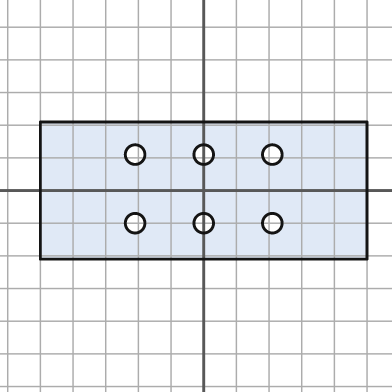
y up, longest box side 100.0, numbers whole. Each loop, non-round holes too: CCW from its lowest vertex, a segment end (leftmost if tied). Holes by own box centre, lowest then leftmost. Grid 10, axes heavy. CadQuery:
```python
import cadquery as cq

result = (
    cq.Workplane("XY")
    .moveTo(-50.0, -21.0)
    .lineTo(50.0, -21.0)
    .lineTo(50.0, 21.0)
    .lineTo(-50.0, 21.0)
    .close()
    .moveTo(-21.0, -10.0)
    .circle(3.0)
    .moveTo(0.0, -10.0)
    .circle(3.0)
    .moveTo(21.0, -10.0)
    .circle(3.0)
    .moveTo(-21.0, 11.0)
    .circle(3.0)
    .moveTo(0.0, 11.0)
    .circle(3.0)
    .moveTo(21.0, 11.0)
    .circle(3.0)
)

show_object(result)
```